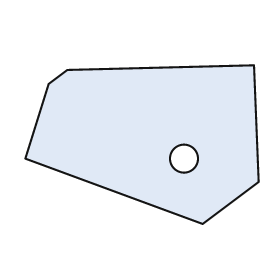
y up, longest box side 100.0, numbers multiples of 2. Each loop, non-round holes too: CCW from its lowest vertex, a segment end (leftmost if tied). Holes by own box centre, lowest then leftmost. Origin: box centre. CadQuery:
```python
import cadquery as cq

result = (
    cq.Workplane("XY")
    .moveTo(26.0, -34.0)
    .lineTo(50.0, -16.0)
    .lineTo(48.0, 34.0)
    .lineTo(-32.0, 32.0)
    .lineTo(-40.0, 26.0)
    .lineTo(-50.0, -6.0)
    .close()
    .moveTo(18.0, -6.0)
    .circle(6.0)
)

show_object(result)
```